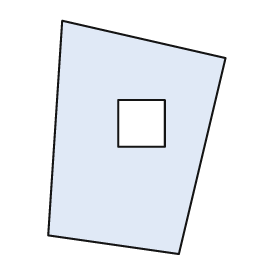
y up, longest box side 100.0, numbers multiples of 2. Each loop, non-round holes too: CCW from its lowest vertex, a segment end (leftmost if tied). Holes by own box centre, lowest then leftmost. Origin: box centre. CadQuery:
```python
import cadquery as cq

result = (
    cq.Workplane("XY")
    .moveTo(18.0, -50.0)
    .lineTo(38.0, 34.0)
    .lineTo(-32.0, 50.0)
    .lineTo(-38.0, -42.0)
    .close()
    .moveTo(-8.0, -4.0)
    .lineTo(12.0, -4.0)
    .lineTo(12.0, 16.0)
    .lineTo(-8.0, 16.0)
    .close()
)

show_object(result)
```